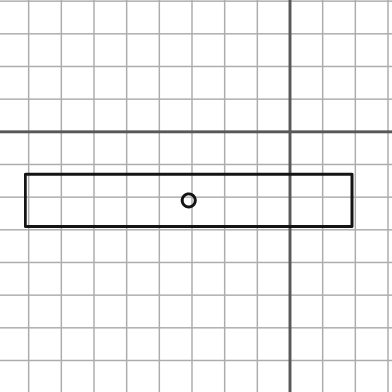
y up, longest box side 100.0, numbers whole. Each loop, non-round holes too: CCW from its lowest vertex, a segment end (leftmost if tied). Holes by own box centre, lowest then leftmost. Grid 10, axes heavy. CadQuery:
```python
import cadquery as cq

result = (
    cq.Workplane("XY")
    .moveTo(-81.0, -29.0)
    .lineTo(19.0, -29.0)
    .lineTo(19.0, -13.0)
    .lineTo(-81.0, -13.0)
    .close()
    .moveTo(-31.0, -21.0)
    .circle(2.0)
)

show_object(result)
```